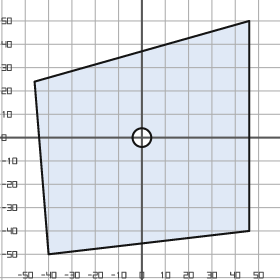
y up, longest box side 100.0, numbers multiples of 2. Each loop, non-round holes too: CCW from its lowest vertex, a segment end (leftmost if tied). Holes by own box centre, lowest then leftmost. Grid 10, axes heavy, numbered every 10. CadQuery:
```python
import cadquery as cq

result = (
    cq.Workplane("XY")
    .moveTo(-40.0, -50.0)
    .lineTo(46.0, -40.0)
    .lineTo(46.0, 50.0)
    .lineTo(-46.0, 24.0)
    .close()
    .moveTo(0.0, 0.0)
    .circle(4.0)
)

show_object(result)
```